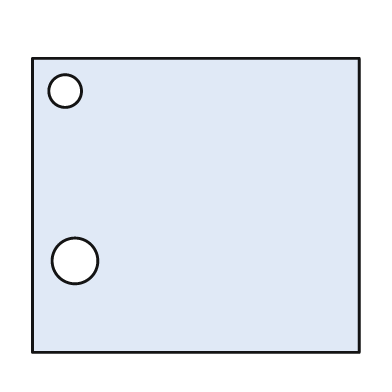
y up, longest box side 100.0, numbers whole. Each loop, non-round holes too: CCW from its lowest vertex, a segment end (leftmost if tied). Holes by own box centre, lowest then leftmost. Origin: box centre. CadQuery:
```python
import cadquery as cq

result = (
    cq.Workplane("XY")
    .moveTo(-50.0, -45.0)
    .lineTo(50.0, -45.0)
    .lineTo(50.0, 45.0)
    .lineTo(-50.0, 45.0)
    .close()
    .moveTo(-37.0, -17.0)
    .circle(7.0)
    .moveTo(-40.0, 35.0)
    .circle(5.0)
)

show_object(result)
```